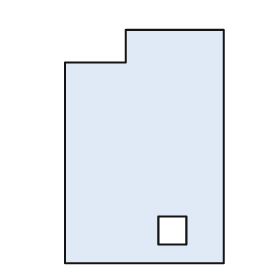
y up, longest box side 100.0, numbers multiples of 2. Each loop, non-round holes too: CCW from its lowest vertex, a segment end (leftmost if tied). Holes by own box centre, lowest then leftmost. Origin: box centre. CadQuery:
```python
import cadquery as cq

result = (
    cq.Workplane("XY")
    .moveTo(-34.0, -50.0)
    .lineTo(34.0, -50.0)
    .lineTo(34.0, 50.0)
    .lineTo(-8.0, 50.0)
    .lineTo(-8.0, 36.0)
    .lineTo(-34.0, 36.0)
    .close()
    .moveTo(6.0, -42.0)
    .lineTo(18.0, -42.0)
    .lineTo(18.0, -30.0)
    .lineTo(6.0, -30.0)
    .close()
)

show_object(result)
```